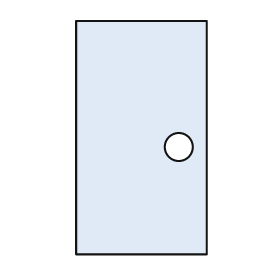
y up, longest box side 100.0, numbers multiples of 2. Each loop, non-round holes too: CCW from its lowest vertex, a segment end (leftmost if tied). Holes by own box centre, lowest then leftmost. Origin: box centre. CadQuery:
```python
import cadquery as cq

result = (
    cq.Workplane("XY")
    .moveTo(-28.0, -50.0)
    .lineTo(28.0, -50.0)
    .lineTo(28.0, 50.0)
    .lineTo(-28.0, 50.0)
    .close()
    .moveTo(16.0, -4.0)
    .circle(6.0)
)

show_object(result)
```